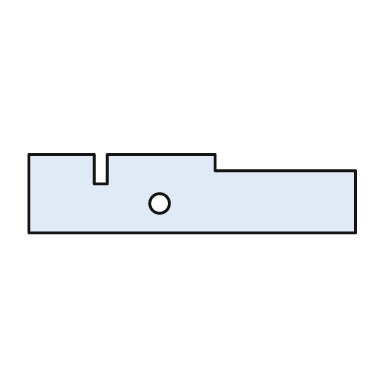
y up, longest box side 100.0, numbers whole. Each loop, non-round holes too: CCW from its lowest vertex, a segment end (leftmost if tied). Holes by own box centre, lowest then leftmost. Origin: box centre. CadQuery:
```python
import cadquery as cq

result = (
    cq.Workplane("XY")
    .moveTo(-50.0, -12.0)
    .lineTo(50.0, -12.0)
    .lineTo(50.0, 7.0)
    .lineTo(7.0, 7.0)
    .lineTo(7.0, 12.0)
    .lineTo(-26.0, 12.0)
    .lineTo(-26.0, 3.0)
    .lineTo(-30.0, 3.0)
    .lineTo(-30.0, 12.0)
    .lineTo(-50.0, 12.0)
    .close()
    .moveTo(-10.0, -3.0)
    .circle(3.0)
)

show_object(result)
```